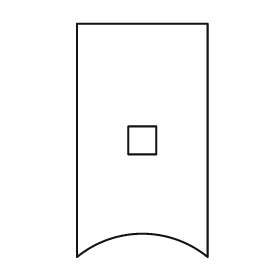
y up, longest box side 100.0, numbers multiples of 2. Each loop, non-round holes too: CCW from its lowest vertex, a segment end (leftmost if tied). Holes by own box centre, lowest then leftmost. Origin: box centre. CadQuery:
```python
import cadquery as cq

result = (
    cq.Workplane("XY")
    .moveTo(-28.0, -50.0)
    .threePointArc((0.0, -40.0), (28.0, -50.0))
    .lineTo(28.0, 50.0)
    .lineTo(-28.0, 50.0)
    .close()
    .moveTo(-6.0, -6.0)
    .lineTo(6.0, -6.0)
    .lineTo(6.0, 6.0)
    .lineTo(-6.0, 6.0)
    .close()
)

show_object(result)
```